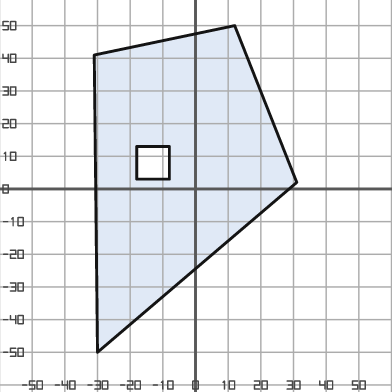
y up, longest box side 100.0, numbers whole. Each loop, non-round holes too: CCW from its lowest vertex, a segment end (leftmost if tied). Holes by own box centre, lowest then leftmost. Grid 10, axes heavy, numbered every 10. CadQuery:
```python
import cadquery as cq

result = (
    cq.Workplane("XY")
    .moveTo(-30.0, -50.0)
    .lineTo(31.0, 2.0)
    .lineTo(12.0, 50.0)
    .lineTo(-31.0, 41.0)
    .close()
    .moveTo(-18.0, 3.0)
    .lineTo(-8.0, 3.0)
    .lineTo(-8.0, 13.0)
    .lineTo(-18.0, 13.0)
    .close()
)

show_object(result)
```